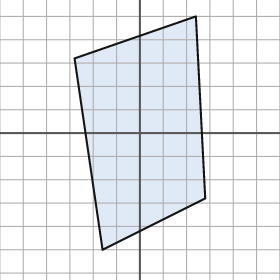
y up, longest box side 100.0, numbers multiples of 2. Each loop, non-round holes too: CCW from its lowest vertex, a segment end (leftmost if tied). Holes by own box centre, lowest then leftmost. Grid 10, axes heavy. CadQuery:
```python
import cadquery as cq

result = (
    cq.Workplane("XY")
    .moveTo(-16.0, -50.0)
    .lineTo(28.0, -28.0)
    .lineTo(24.0, 50.0)
    .lineTo(-28.0, 32.0)
    .close()
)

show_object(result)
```